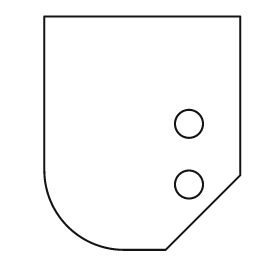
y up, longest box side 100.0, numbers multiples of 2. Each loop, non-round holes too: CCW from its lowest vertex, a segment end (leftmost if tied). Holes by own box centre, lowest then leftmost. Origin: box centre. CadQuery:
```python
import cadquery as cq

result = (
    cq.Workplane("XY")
    .moveTo(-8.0, -50.0)
    .lineTo(10.0, -50.0)
    .lineTo(42.0, -18.0)
    .lineTo(42.0, 50.0)
    .lineTo(-42.0, 50.0)
    .lineTo(-42.0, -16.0)
    .threePointArc((-32.0, -40.0), (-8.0, -50.0))
    .close()
    .moveTo(20.0, -22.0)
    .circle(6.0)
    .moveTo(20.0, 4.0)
    .circle(6.0)
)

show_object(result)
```